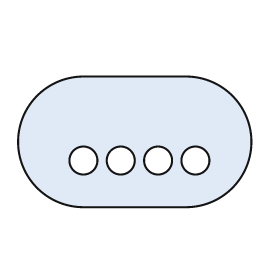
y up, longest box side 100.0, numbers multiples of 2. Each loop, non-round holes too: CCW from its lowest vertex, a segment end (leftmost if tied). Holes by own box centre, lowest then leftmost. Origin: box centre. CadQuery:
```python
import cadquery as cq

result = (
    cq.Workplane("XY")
    .moveTo(-22.0, -28.0)
    .lineTo(22.0, -28.0)
    .threePointArc((50.0, 0.0), (22.0, 28.0))
    .lineTo(-22.0, 28.0)
    .threePointArc((-50.0, 0.0), (-22.0, -28.0))
    .close()
    .moveTo(-22.0, -8.0)
    .circle(6.0)
    .moveTo(-6.0, -8.0)
    .circle(6.0)
    .moveTo(10.0, -8.0)
    .circle(6.0)
    .moveTo(26.0, -8.0)
    .circle(6.0)
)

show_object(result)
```